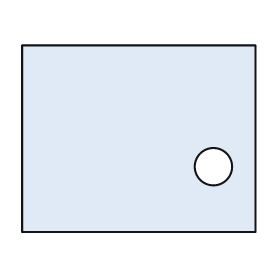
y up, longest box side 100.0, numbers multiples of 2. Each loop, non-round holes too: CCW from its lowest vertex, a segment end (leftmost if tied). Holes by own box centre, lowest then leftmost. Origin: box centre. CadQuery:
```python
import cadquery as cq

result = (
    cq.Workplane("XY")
    .moveTo(-50.0, -40.0)
    .lineTo(50.0, -40.0)
    .lineTo(50.0, 40.0)
    .lineTo(-50.0, 40.0)
    .close()
    .moveTo(32.0, -12.0)
    .circle(8.0)
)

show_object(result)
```